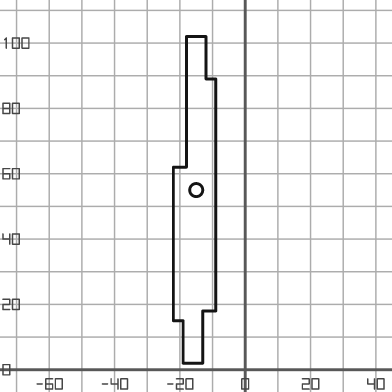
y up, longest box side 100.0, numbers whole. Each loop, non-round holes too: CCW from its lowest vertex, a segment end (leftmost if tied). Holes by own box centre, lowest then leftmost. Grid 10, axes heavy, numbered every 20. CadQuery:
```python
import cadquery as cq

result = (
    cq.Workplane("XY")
    .moveTo(-19.0, 2.0)
    .lineTo(-13.0, 2.0)
    .lineTo(-13.0, 18.0)
    .lineTo(-9.0, 18.0)
    .lineTo(-9.0, 89.0)
    .lineTo(-12.0, 89.0)
    .lineTo(-12.0, 102.0)
    .lineTo(-18.0, 102.0)
    .lineTo(-18.0, 62.0)
    .lineTo(-22.0, 62.0)
    .lineTo(-22.0, 15.0)
    .lineTo(-19.0, 15.0)
    .close()
    .moveTo(-15.0, 55.0)
    .circle(2.0)
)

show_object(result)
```